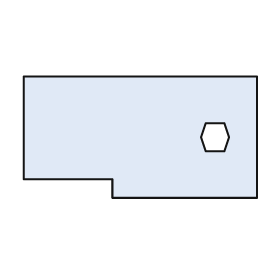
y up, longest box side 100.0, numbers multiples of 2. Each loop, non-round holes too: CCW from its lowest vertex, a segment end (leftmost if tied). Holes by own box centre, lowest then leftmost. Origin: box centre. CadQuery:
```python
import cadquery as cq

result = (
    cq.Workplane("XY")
    .moveTo(-12.0, -26.0)
    .lineTo(50.0, -26.0)
    .lineTo(50.0, 26.0)
    .lineTo(-50.0, 26.0)
    .lineTo(-50.0, -18.0)
    .lineTo(-12.0, -18.0)
    .close()
    .moveTo(28.0, -6.0)
    .lineTo(36.0, -6.0)
    .lineTo(38.0, 0.0)
    .lineTo(36.0, 6.0)
    .lineTo(28.0, 6.0)
    .lineTo(26.0, 0.0)
    .close()
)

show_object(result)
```